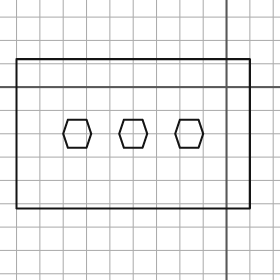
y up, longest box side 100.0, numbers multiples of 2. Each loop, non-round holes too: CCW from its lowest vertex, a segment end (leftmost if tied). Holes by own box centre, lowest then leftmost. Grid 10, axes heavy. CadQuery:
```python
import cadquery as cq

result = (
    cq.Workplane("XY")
    .moveTo(-90.0, -52.0)
    .lineTo(10.0, -52.0)
    .lineTo(10.0, 12.0)
    .lineTo(-90.0, 12.0)
    .close()
    .moveTo(-68.0, -26.0)
    .lineTo(-60.0, -26.0)
    .lineTo(-58.0, -20.0)
    .lineTo(-60.0, -14.0)
    .lineTo(-68.0, -14.0)
    .lineTo(-70.0, -20.0)
    .close()
    .moveTo(-44.0, -26.0)
    .lineTo(-36.0, -26.0)
    .lineTo(-34.0, -20.0)
    .lineTo(-36.0, -14.0)
    .lineTo(-44.0, -14.0)
    .lineTo(-46.0, -20.0)
    .close()
    .moveTo(-20.0, -26.0)
    .lineTo(-12.0, -26.0)
    .lineTo(-10.0, -20.0)
    .lineTo(-12.0, -14.0)
    .lineTo(-20.0, -14.0)
    .lineTo(-22.0, -20.0)
    .close()
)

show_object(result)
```